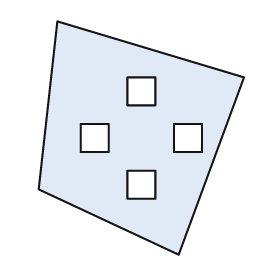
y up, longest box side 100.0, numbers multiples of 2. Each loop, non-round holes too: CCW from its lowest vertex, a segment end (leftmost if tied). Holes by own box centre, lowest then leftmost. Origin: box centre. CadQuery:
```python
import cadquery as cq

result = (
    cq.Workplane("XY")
    .moveTo(16.0, -50.0)
    .lineTo(44.0, 26.0)
    .lineTo(-36.0, 50.0)
    .lineTo(-44.0, -22.0)
    .close()
    .moveTo(-6.0, -26.0)
    .lineTo(6.0, -26.0)
    .lineTo(6.0, -14.0)
    .lineTo(-6.0, -14.0)
    .close()
    .moveTo(-26.0, -6.0)
    .lineTo(-14.0, -6.0)
    .lineTo(-14.0, 6.0)
    .lineTo(-26.0, 6.0)
    .close()
    .moveTo(14.0, -6.0)
    .lineTo(26.0, -6.0)
    .lineTo(26.0, 6.0)
    .lineTo(14.0, 6.0)
    .close()
    .moveTo(-6.0, 14.0)
    .lineTo(6.0, 14.0)
    .lineTo(6.0, 26.0)
    .lineTo(-6.0, 26.0)
    .close()
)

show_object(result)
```